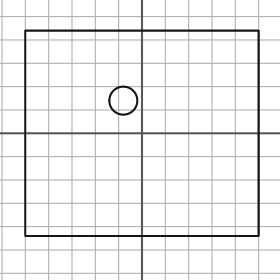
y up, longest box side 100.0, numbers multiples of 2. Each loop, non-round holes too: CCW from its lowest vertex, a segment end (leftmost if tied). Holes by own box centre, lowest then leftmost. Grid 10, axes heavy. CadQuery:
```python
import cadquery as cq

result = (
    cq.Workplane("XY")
    .moveTo(-50.0, -44.0)
    .lineTo(50.0, -44.0)
    .lineTo(50.0, 44.0)
    .lineTo(-50.0, 44.0)
    .close()
    .moveTo(-8.0, 14.0)
    .circle(6.0)
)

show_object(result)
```